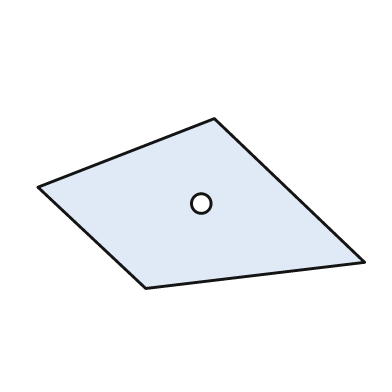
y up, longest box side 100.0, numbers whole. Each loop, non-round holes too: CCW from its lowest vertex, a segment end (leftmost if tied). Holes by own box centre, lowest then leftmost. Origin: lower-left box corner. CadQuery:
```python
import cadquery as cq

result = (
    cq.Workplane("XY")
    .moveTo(33.0, 0.0)
    .lineTo(100.0, 8.0)
    .lineTo(54.0, 52.0)
    .lineTo(0.0, 31.0)
    .close()
    .moveTo(50.0, 26.0)
    .circle(3.0)
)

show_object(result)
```